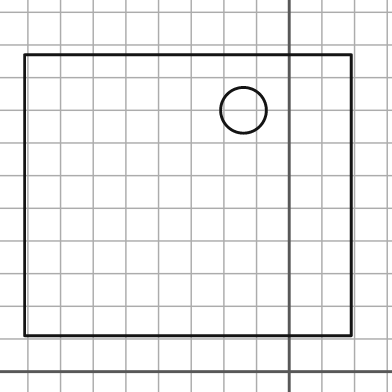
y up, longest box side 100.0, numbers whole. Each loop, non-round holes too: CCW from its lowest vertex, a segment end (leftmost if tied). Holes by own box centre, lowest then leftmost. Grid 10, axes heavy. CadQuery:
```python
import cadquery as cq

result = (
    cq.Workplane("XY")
    .moveTo(-81.0, 11.0)
    .lineTo(19.0, 11.0)
    .lineTo(19.0, 97.0)
    .lineTo(-81.0, 97.0)
    .close()
    .moveTo(-14.0, 80.0)
    .circle(7.0)
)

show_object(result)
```